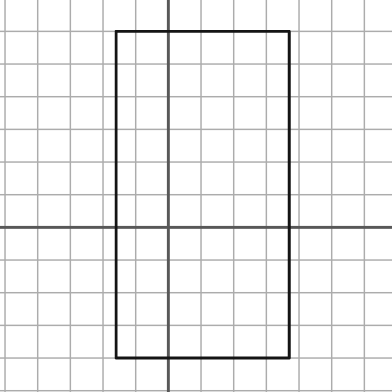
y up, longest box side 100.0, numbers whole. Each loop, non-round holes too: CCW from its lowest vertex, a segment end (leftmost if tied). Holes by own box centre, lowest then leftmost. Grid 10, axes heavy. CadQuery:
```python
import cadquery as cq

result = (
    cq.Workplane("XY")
    .moveTo(-16.0, -40.0)
    .lineTo(37.0, -40.0)
    .lineTo(37.0, 60.0)
    .lineTo(-16.0, 60.0)
    .close()
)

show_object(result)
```